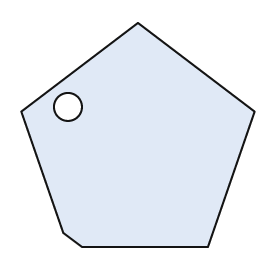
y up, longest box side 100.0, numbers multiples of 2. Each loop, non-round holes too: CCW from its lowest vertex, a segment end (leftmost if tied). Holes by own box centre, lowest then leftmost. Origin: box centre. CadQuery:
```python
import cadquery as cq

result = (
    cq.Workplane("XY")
    .moveTo(-24.0, -48.0)
    .lineTo(30.0, -48.0)
    .lineTo(50.0, 10.0)
    .lineTo(0.0, 48.0)
    .lineTo(-50.0, 10.0)
    .lineTo(-32.0, -42.0)
    .close()
    .moveTo(-30.0, 12.0)
    .circle(6.0)
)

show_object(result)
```